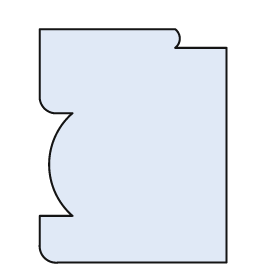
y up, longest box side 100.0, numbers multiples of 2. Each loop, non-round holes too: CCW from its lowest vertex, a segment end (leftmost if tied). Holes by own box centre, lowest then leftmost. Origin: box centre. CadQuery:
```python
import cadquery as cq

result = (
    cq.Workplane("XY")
    .moveTo(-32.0, -50.0)
    .lineTo(40.0, -50.0)
    .lineTo(40.0, 42.0)
    .lineTo(18.0, 42.0)
    .threePointArc((20.0, 46.0), (18.0, 50.0))
    .lineTo(-40.0, 50.0)
    .lineTo(-40.0, 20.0)
    .threePointArc((-38.0, 16.0), (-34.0, 14.0))
    .lineTo(-26.0, 14.0)
    .threePointArc((-36.0, -8.0), (-26.0, -30.0))
    .lineTo(-40.0, -30.0)
    .lineTo(-40.0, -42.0)
    .threePointArc((-38.0, -48.0), (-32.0, -50.0))
    .close()
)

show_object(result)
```